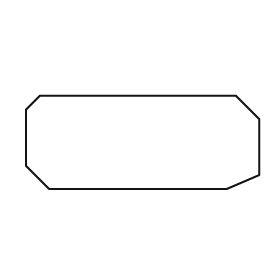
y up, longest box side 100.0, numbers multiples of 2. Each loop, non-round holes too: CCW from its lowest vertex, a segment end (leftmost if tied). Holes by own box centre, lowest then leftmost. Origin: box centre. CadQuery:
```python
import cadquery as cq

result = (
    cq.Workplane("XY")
    .moveTo(-40.0, -20.0)
    .lineTo(36.0, -20.0)
    .lineTo(50.0, -14.0)
    .lineTo(50.0, 10.0)
    .lineTo(40.0, 20.0)
    .lineTo(-44.0, 20.0)
    .lineTo(-50.0, 14.0)
    .lineTo(-50.0, -10.0)
    .close()
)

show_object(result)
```